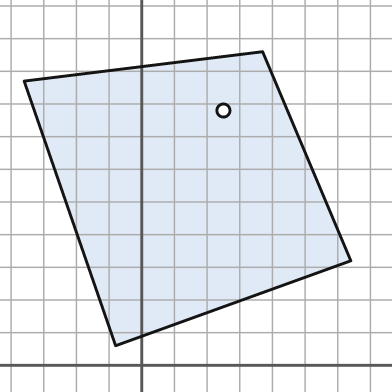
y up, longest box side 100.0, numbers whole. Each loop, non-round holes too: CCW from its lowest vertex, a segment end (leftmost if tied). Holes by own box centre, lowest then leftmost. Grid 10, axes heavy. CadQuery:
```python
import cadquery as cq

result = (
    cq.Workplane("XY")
    .moveTo(-8.0, 6.0)
    .lineTo(64.0, 32.0)
    .lineTo(37.0, 96.0)
    .lineTo(-36.0, 87.0)
    .close()
    .moveTo(25.0, 78.0)
    .circle(2.0)
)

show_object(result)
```